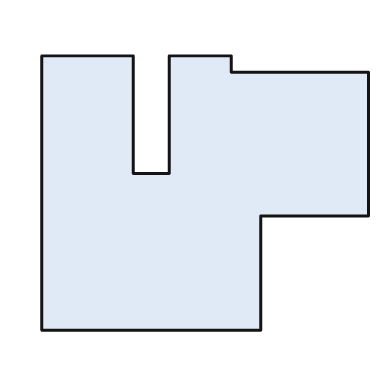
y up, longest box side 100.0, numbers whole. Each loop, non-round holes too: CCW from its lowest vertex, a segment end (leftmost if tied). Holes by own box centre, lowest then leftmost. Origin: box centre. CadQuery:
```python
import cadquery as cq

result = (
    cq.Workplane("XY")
    .moveTo(-50.0, -42.0)
    .lineTo(17.0, -42.0)
    .lineTo(17.0, -7.0)
    .lineTo(50.0, -7.0)
    .lineTo(50.0, 37.0)
    .lineTo(8.0, 37.0)
    .lineTo(8.0, 42.0)
    .lineTo(-11.0, 42.0)
    .lineTo(-11.0, 6.0)
    .lineTo(-22.0, 6.0)
    .lineTo(-22.0, 42.0)
    .lineTo(-50.0, 42.0)
    .close()
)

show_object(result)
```